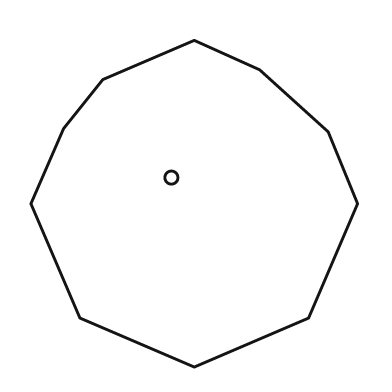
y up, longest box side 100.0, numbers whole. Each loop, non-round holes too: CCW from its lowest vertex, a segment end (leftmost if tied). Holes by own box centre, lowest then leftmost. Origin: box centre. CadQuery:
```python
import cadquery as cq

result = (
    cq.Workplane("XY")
    .moveTo(0.0, -50.0)
    .lineTo(35.0, -35.0)
    .lineTo(50.0, 0.0)
    .lineTo(41.0, 22.0)
    .lineTo(20.0, 41.0)
    .lineTo(0.0, 50.0)
    .lineTo(-28.0, 38.0)
    .lineTo(-40.0, 23.0)
    .lineTo(-50.0, 0.0)
    .lineTo(-35.0, -35.0)
    .close()
    .moveTo(-7.0, 8.0)
    .circle(2.0)
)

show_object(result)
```